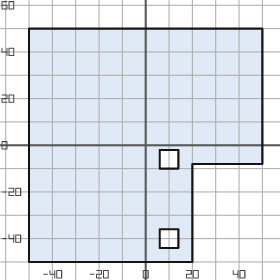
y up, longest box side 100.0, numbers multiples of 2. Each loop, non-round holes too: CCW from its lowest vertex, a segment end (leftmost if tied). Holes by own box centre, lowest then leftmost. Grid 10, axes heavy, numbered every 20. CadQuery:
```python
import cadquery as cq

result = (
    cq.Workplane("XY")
    .moveTo(-50.0, -50.0)
    .lineTo(20.0, -50.0)
    .lineTo(20.0, -8.0)
    .lineTo(50.0, -8.0)
    .lineTo(50.0, 50.0)
    .lineTo(-50.0, 50.0)
    .close()
    .moveTo(6.0, -44.0)
    .lineTo(14.0, -44.0)
    .lineTo(14.0, -36.0)
    .lineTo(6.0, -36.0)
    .close()
    .moveTo(6.0, -10.0)
    .lineTo(14.0, -10.0)
    .lineTo(14.0, -2.0)
    .lineTo(6.0, -2.0)
    .close()
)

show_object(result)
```